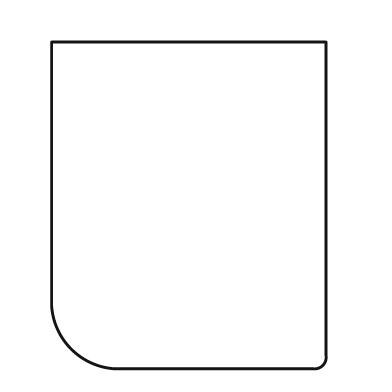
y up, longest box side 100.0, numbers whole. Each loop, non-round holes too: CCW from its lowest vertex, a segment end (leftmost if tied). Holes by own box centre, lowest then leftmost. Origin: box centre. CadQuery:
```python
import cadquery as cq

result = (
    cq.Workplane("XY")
    .moveTo(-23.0, -50.0)
    .lineTo(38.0, -50.0)
    .threePointArc((41.0, -49.0), (42.0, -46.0))
    .lineTo(42.0, 50.0)
    .lineTo(-42.0, 50.0)
    .lineTo(-42.0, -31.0)
    .threePointArc((-36.0, -44.0), (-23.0, -50.0))
    .close()
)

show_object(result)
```